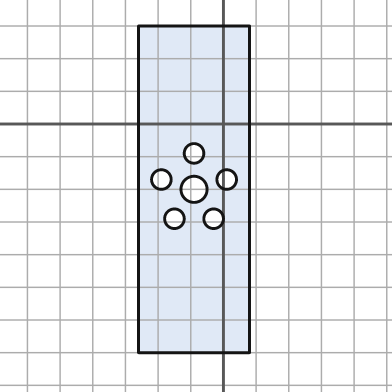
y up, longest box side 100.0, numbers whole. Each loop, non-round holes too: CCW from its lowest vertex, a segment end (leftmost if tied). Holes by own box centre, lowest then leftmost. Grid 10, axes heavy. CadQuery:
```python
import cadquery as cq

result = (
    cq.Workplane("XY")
    .moveTo(-26.0, -70.0)
    .lineTo(8.0, -70.0)
    .lineTo(8.0, 30.0)
    .lineTo(-26.0, 30.0)
    .close()
    .moveTo(-15.0, -29.0)
    .circle(3.0)
    .moveTo(-3.0, -29.0)
    .circle(3.0)
    .moveTo(-9.0, -20.0)
    .circle(4.0)
    .moveTo(-19.0, -17.0)
    .circle(3.0)
    .moveTo(1.0, -17.0)
    .circle(3.0)
    .moveTo(-9.0, -9.0)
    .circle(3.0)
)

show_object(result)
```